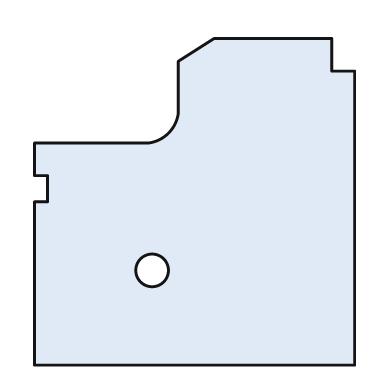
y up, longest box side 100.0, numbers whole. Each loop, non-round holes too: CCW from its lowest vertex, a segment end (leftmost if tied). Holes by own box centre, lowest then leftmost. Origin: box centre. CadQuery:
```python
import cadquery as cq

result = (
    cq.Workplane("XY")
    .moveTo(-49.0, -50.0)
    .lineTo(49.0, -50.0)
    .lineTo(49.0, 40.0)
    .lineTo(42.0, 40.0)
    .lineTo(42.0, 50.0)
    .lineTo(6.0, 50.0)
    .lineTo(-5.0, 43.0)
    .lineTo(-5.0, 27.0)
    .threePointArc((-8.0, 21.0), (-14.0, 18.0))
    .lineTo(-49.0, 18.0)
    .lineTo(-49.0, 8.0)
    .lineTo(-45.0, 8.0)
    .lineTo(-45.0, 0.0)
    .lineTo(-49.0, 0.0)
    .close()
    .moveTo(-13.0, -21.0)
    .circle(5.0)
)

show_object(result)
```